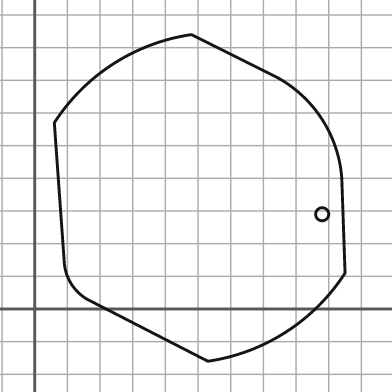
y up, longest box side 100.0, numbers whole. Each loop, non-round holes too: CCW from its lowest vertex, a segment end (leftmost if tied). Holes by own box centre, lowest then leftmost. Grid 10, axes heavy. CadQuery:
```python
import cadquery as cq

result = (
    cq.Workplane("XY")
    .moveTo(53.0, -16.0)
    .threePointArc((77.0, -7.0), (95.0, 11.0))
    .lineTo(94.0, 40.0)
    .threePointArc((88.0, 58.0), (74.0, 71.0))
    .lineTo(48.0, 84.0)
    .threePointArc((24.0, 75.0), (6.0, 57.0))
    .lineTo(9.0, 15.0)
    .threePointArc((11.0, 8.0), (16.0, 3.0))
    .close()
    .moveTo(88.0, 29.0)
    .circle(2.0)
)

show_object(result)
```